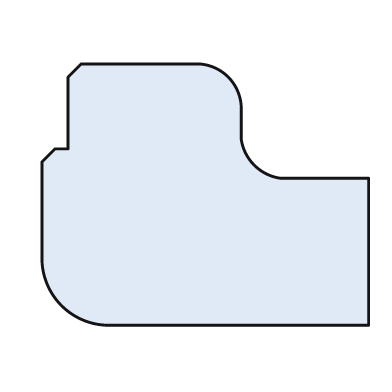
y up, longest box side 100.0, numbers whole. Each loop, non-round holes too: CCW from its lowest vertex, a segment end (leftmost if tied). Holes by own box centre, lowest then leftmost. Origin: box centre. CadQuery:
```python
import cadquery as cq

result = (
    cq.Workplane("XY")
    .moveTo(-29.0, -40.0)
    .lineTo(50.0, -40.0)
    .lineTo(50.0, 5.0)
    .lineTo(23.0, 5.0)
    .threePointArc((15.0, 9.0), (11.0, 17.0))
    .lineTo(11.0, 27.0)
    .threePointArc((7.0, 36.0), (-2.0, 40.0))
    .lineTo(-38.0, 40.0)
    .lineTo(-42.0, 36.0)
    .lineTo(-42.0, 14.0)
    .lineTo(-46.0, 14.0)
    .lineTo(-50.0, 10.0)
    .lineTo(-50.0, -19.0)
    .threePointArc((-44.0, -34.0), (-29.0, -40.0))
    .close()
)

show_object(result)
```